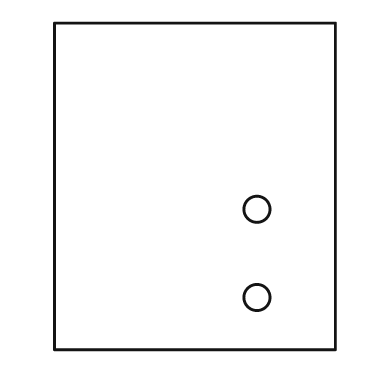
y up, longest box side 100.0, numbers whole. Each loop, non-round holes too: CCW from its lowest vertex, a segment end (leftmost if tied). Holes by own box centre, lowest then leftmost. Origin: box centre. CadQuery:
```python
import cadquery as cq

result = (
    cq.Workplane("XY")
    .moveTo(-43.0, -50.0)
    .lineTo(43.0, -50.0)
    .lineTo(43.0, 50.0)
    .lineTo(-43.0, 50.0)
    .close()
    .moveTo(19.0, -34.0)
    .circle(4.0)
    .moveTo(19.0, -7.0)
    .circle(4.0)
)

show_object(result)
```